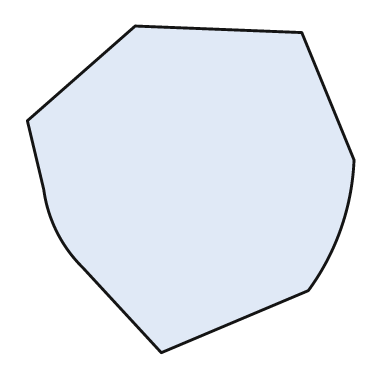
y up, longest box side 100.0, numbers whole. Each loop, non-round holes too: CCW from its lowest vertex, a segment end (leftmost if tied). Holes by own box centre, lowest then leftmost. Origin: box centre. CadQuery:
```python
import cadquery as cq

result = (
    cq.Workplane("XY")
    .moveTo(-9.0, -50.0)
    .lineTo(36.0, -31.0)
    .threePointArc((46.0, -12.0), (50.0, 9.0))
    .lineTo(34.0, 48.0)
    .lineTo(-17.0, 50.0)
    .lineTo(-50.0, 21.0)
    .lineTo(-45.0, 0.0)
    .threePointArc((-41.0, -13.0), (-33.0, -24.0))
    .close()
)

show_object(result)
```